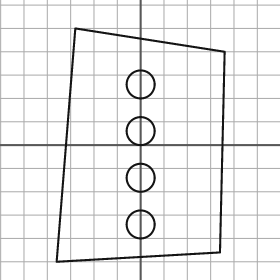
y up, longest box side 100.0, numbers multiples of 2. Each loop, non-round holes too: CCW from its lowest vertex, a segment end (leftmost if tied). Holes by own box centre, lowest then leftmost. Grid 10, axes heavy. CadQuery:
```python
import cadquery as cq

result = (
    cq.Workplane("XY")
    .moveTo(-36.0, -50.0)
    .lineTo(34.0, -46.0)
    .lineTo(36.0, 40.0)
    .lineTo(-28.0, 50.0)
    .close()
    .moveTo(0.0, -34.0)
    .circle(6.0)
    .moveTo(0.0, -14.0)
    .circle(6.0)
    .moveTo(0.0, 6.0)
    .circle(6.0)
    .moveTo(0.0, 26.0)
    .circle(6.0)
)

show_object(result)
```